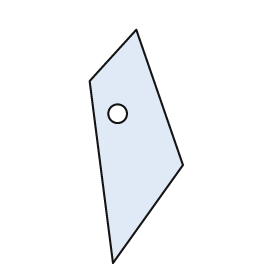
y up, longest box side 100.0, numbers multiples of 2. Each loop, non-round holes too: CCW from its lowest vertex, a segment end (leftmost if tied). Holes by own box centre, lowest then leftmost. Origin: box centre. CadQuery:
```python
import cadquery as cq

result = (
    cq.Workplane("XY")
    .moveTo(-10.0, -50.0)
    .lineTo(20.0, -8.0)
    .lineTo(0.0, 50.0)
    .lineTo(-20.0, 28.0)
    .close()
    .moveTo(-8.0, 14.0)
    .circle(4.0)
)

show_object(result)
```